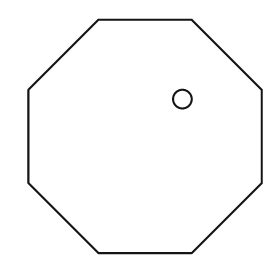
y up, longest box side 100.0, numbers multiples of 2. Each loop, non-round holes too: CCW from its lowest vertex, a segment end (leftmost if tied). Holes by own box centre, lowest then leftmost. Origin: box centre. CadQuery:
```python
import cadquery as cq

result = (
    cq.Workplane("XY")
    .moveTo(-20.0, -50.0)
    .lineTo(20.0, -50.0)
    .lineTo(50.0, -20.0)
    .lineTo(50.0, 20.0)
    .lineTo(20.0, 50.0)
    .lineTo(-20.0, 50.0)
    .lineTo(-50.0, 20.0)
    .lineTo(-50.0, -20.0)
    .close()
    .moveTo(16.0, 16.0)
    .circle(4.0)
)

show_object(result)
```